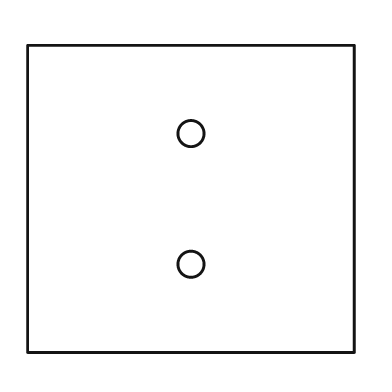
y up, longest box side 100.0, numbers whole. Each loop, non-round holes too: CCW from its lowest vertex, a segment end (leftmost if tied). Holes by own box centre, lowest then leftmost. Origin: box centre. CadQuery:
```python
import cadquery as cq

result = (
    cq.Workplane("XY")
    .moveTo(-50.0, -47.0)
    .lineTo(50.0, -47.0)
    .lineTo(50.0, 47.0)
    .lineTo(-50.0, 47.0)
    .close()
    .moveTo(0.0, -20.0)
    .circle(4.0)
    .moveTo(0.0, 20.0)
    .circle(4.0)
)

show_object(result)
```